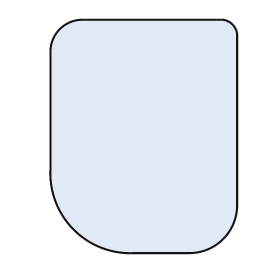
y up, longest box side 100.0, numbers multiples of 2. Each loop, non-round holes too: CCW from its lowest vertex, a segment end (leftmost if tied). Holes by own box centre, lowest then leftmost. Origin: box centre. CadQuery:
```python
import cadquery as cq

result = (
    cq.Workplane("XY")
    .moveTo(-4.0, -50.0)
    .lineTo(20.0, -50.0)
    .threePointArc((34.0, -44.0), (40.0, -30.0))
    .lineTo(40.0, 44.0)
    .threePointArc((38.0, 48.0), (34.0, 50.0))
    .lineTo(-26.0, 50.0)
    .threePointArc((-36.0, 46.0), (-40.0, 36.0))
    .lineTo(-40.0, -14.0)
    .threePointArc((-30.0, -40.0), (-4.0, -50.0))
    .close()
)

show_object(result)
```